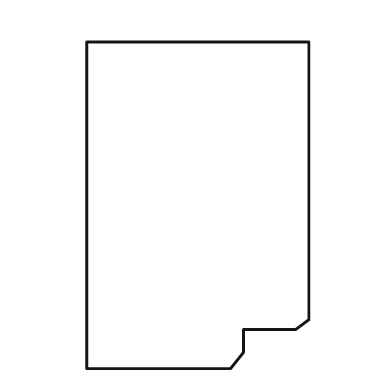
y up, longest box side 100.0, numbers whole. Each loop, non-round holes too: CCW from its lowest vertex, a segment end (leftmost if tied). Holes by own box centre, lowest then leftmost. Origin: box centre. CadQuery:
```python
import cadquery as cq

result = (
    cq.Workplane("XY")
    .moveTo(-34.0, -50.0)
    .lineTo(10.0, -50.0)
    .lineTo(14.0, -45.0)
    .lineTo(14.0, -38.0)
    .lineTo(30.0, -38.0)
    .lineTo(34.0, -35.0)
    .lineTo(34.0, 50.0)
    .lineTo(-34.0, 50.0)
    .close()
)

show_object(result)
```